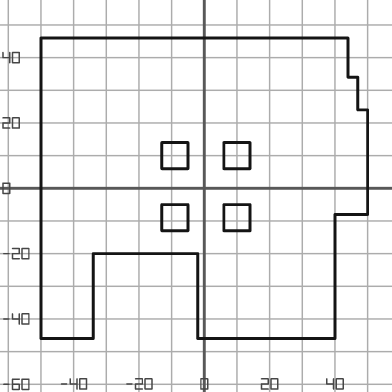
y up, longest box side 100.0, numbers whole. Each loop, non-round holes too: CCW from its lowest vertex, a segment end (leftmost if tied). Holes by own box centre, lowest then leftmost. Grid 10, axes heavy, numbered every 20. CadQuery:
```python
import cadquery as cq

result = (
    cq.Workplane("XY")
    .moveTo(-50.0, -46.0)
    .lineTo(-34.0, -46.0)
    .lineTo(-34.0, -20.0)
    .lineTo(-2.0, -20.0)
    .lineTo(-2.0, -46.0)
    .lineTo(40.0, -46.0)
    .lineTo(40.0, -8.0)
    .lineTo(50.0, -8.0)
    .lineTo(50.0, 24.0)
    .lineTo(47.0, 24.0)
    .lineTo(47.0, 34.0)
    .lineTo(44.0, 34.0)
    .lineTo(44.0, 46.0)
    .lineTo(-50.0, 46.0)
    .close()
    .moveTo(-13.0, -13.0)
    .lineTo(-5.0, -13.0)
    .lineTo(-5.0, -5.0)
    .lineTo(-13.0, -5.0)
    .close()
    .moveTo(6.0, -13.0)
    .lineTo(14.0, -13.0)
    .lineTo(14.0, -5.0)
    .lineTo(6.0, -5.0)
    .close()
    .moveTo(-13.0, 6.0)
    .lineTo(-5.0, 6.0)
    .lineTo(-5.0, 14.0)
    .lineTo(-13.0, 14.0)
    .close()
    .moveTo(6.0, 6.0)
    .lineTo(14.0, 6.0)
    .lineTo(14.0, 14.0)
    .lineTo(6.0, 14.0)
    .close()
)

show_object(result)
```